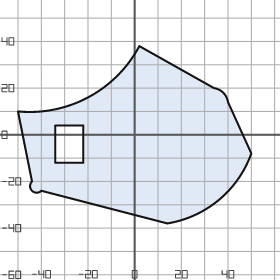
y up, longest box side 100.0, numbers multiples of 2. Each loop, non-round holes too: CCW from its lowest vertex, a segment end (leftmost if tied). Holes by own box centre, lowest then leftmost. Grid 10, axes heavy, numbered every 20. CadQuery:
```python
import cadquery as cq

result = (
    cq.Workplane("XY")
    .moveTo(14.0, -38.0)
    .threePointArc((36.0, -28.0), (50.0, -8.0))
    .lineTo(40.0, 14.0)
    .threePointArc((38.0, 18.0), (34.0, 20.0))
    .lineTo(2.0, 38.0)
    .threePointArc((-20.0, 16.0), (-50.0, 10.0))
    .lineTo(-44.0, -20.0)
    .threePointArc((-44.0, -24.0), (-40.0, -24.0))
    .close()
    .moveTo(-34.0, -12.0)
    .lineTo(-22.0, -12.0)
    .lineTo(-22.0, 4.0)
    .lineTo(-34.0, 4.0)
    .close()
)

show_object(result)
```